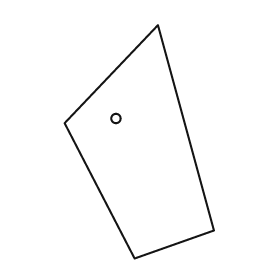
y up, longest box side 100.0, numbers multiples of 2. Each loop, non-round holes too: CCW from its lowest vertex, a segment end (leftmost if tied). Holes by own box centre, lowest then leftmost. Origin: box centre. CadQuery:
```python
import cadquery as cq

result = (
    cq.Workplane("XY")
    .moveTo(-2.0, -50.0)
    .lineTo(32.0, -38.0)
    .lineTo(8.0, 50.0)
    .lineTo(-32.0, 8.0)
    .close()
    .moveTo(-10.0, 10.0)
    .circle(2.0)
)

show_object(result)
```